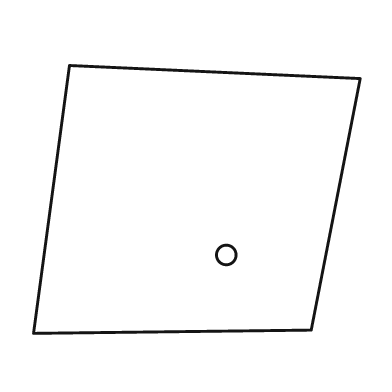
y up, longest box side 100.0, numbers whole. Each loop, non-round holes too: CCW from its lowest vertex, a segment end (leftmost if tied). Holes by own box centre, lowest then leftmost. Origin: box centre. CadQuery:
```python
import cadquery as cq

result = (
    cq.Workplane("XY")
    .moveTo(-50.0, -41.0)
    .lineTo(35.0, -40.0)
    .lineTo(50.0, 37.0)
    .lineTo(-39.0, 41.0)
    .close()
    .moveTo(9.0, -17.0)
    .circle(3.0)
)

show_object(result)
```